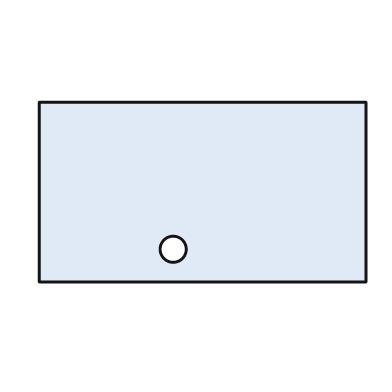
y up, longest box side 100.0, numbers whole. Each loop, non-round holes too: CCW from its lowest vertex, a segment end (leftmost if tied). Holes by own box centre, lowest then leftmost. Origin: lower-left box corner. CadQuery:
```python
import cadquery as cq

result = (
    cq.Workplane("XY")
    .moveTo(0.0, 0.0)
    .lineTo(100.0, 0.0)
    .lineTo(100.0, 55.0)
    .lineTo(0.0, 55.0)
    .close()
    .moveTo(41.0, 10.0)
    .circle(4.0)
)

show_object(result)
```